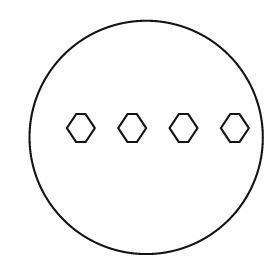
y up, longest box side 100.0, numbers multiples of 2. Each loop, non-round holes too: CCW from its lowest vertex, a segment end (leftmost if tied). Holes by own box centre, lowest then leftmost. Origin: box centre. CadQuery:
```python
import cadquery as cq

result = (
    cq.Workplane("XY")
    .moveTo(0.0, 0.0)
    .circle(50.0)
    .moveTo(-30.0, -2.0)
    .lineTo(-26.0, -2.0)
    .lineTo(-22.0, 4.0)
    .lineTo(-26.0, 10.0)
    .lineTo(-30.0, 10.0)
    .lineTo(-34.0, 4.0)
    .close()
    .moveTo(-8.0, -2.0)
    .lineTo(-4.0, -2.0)
    .lineTo(0.0, 4.0)
    .lineTo(-4.0, 10.0)
    .lineTo(-8.0, 10.0)
    .lineTo(-12.0, 4.0)
    .close()
    .moveTo(14.0, -2.0)
    .lineTo(18.0, -2.0)
    .lineTo(22.0, 4.0)
    .lineTo(18.0, 10.0)
    .lineTo(14.0, 10.0)
    .lineTo(10.0, 4.0)
    .close()
    .moveTo(36.0, -2.0)
    .lineTo(40.0, -2.0)
    .lineTo(44.0, 4.0)
    .lineTo(40.0, 10.0)
    .lineTo(36.0, 10.0)
    .lineTo(32.0, 4.0)
    .close()
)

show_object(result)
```